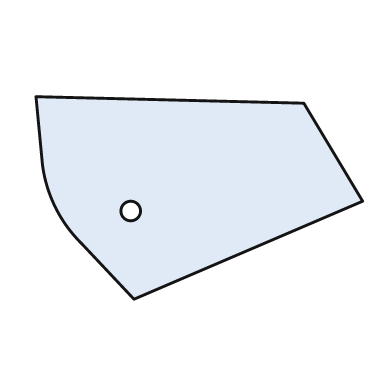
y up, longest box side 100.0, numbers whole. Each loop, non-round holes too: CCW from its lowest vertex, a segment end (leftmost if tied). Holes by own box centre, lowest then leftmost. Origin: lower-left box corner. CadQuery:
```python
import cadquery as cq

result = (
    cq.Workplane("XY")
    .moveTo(30.0, 0.0)
    .lineTo(100.0, 30.0)
    .lineTo(82.0, 60.0)
    .lineTo(0.0, 62.0)
    .lineTo(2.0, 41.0)
    .threePointArc((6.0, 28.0), (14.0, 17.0))
    .close()
    .moveTo(29.0, 27.0)
    .circle(3.0)
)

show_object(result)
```